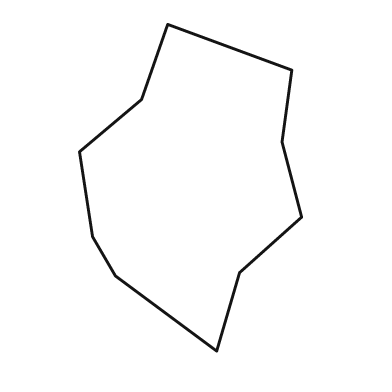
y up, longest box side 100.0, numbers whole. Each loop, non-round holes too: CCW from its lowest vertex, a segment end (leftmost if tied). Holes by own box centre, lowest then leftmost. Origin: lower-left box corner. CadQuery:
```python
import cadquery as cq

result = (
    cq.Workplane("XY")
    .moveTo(42.0, 0.0)
    .lineTo(49.0, 24.0)
    .lineTo(68.0, 41.0)
    .lineTo(62.0, 64.0)
    .lineTo(65.0, 86.0)
    .lineTo(27.0, 100.0)
    .lineTo(19.0, 77.0)
    .lineTo(0.0, 61.0)
    .lineTo(4.0, 35.0)
    .lineTo(11.0, 23.0)
    .close()
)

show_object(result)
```